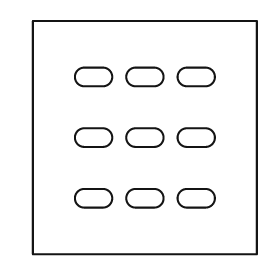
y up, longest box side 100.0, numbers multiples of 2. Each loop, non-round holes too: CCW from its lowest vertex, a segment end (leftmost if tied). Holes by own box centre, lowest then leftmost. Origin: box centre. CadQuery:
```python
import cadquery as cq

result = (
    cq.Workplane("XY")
    .moveTo(-48.0, -50.0)
    .lineTo(48.0, -50.0)
    .lineTo(48.0, 50.0)
    .lineTo(-48.0, 50.0)
    .close()
    .moveTo(-26.0, -30.0)
    .lineTo(-18.0, -30.0)
    .threePointArc((-14.0, -26.0), (-18.0, -22.0))
    .lineTo(-26.0, -22.0)
    .threePointArc((-30.0, -26.0), (-26.0, -30.0))
    .close()
    .moveTo(-4.0, -30.0)
    .lineTo(4.0, -30.0)
    .threePointArc((8.0, -26.0), (4.0, -22.0))
    .lineTo(-4.0, -22.0)
    .threePointArc((-8.0, -26.0), (-4.0, -30.0))
    .close()
    .moveTo(18.0, -30.0)
    .lineTo(26.0, -30.0)
    .threePointArc((30.0, -26.0), (26.0, -22.0))
    .lineTo(18.0, -22.0)
    .threePointArc((14.0, -26.0), (18.0, -30.0))
    .close()
    .moveTo(-26.0, -4.0)
    .lineTo(-18.0, -4.0)
    .threePointArc((-14.0, 0.0), (-18.0, 4.0))
    .lineTo(-26.0, 4.0)
    .threePointArc((-30.0, 0.0), (-26.0, -4.0))
    .close()
    .moveTo(-4.0, -4.0)
    .lineTo(4.0, -4.0)
    .threePointArc((8.0, 0.0), (4.0, 4.0))
    .lineTo(-4.0, 4.0)
    .threePointArc((-8.0, 0.0), (-4.0, -4.0))
    .close()
    .moveTo(18.0, -4.0)
    .lineTo(26.0, -4.0)
    .threePointArc((30.0, 0.0), (26.0, 4.0))
    .lineTo(18.0, 4.0)
    .threePointArc((14.0, 0.0), (18.0, -4.0))
    .close()
    .moveTo(-26.0, 22.0)
    .lineTo(-18.0, 22.0)
    .threePointArc((-14.0, 26.0), (-18.0, 30.0))
    .lineTo(-26.0, 30.0)
    .threePointArc((-30.0, 26.0), (-26.0, 22.0))
    .close()
    .moveTo(-4.0, 22.0)
    .lineTo(4.0, 22.0)
    .threePointArc((8.0, 26.0), (4.0, 30.0))
    .lineTo(-4.0, 30.0)
    .threePointArc((-8.0, 26.0), (-4.0, 22.0))
    .close()
    .moveTo(18.0, 22.0)
    .lineTo(26.0, 22.0)
    .threePointArc((30.0, 26.0), (26.0, 30.0))
    .lineTo(18.0, 30.0)
    .threePointArc((14.0, 26.0), (18.0, 22.0))
    .close()
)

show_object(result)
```